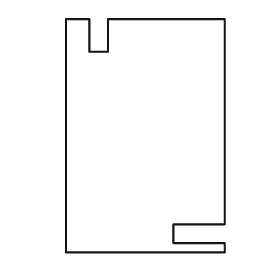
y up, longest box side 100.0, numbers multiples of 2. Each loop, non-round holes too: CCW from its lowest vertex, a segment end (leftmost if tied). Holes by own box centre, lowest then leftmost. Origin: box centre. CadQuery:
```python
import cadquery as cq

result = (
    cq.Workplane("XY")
    .moveTo(-34.0, -50.0)
    .lineTo(34.0, -50.0)
    .lineTo(34.0, -46.0)
    .lineTo(12.0, -46.0)
    .lineTo(12.0, -38.0)
    .lineTo(34.0, -38.0)
    .lineTo(34.0, 50.0)
    .lineTo(-16.0, 50.0)
    .lineTo(-16.0, 36.0)
    .lineTo(-24.0, 36.0)
    .lineTo(-24.0, 50.0)
    .lineTo(-34.0, 50.0)
    .close()
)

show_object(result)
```